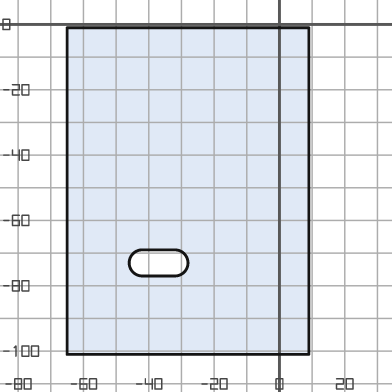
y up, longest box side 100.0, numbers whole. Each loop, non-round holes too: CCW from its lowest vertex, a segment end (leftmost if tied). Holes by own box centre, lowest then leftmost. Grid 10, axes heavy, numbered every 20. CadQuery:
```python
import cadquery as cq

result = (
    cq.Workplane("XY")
    .moveTo(-65.0, -101.0)
    .lineTo(9.0, -101.0)
    .lineTo(9.0, -1.0)
    .lineTo(-65.0, -1.0)
    .close()
    .moveTo(-42.0, -77.0)
    .lineTo(-32.0, -77.0)
    .threePointArc((-28.0, -73.0), (-32.0, -69.0))
    .lineTo(-42.0, -69.0)
    .threePointArc((-46.0, -73.0), (-42.0, -77.0))
    .close()
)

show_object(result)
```